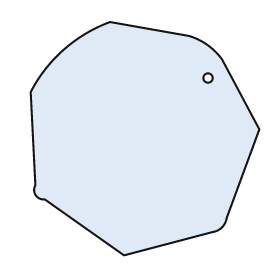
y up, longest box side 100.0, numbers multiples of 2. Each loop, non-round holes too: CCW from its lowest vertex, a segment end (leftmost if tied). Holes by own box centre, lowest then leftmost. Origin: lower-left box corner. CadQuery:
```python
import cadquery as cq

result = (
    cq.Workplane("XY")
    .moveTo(40.0, 0.0)
    .lineTo(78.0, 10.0)
    .threePointArc((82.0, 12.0), (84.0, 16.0))
    .lineTo(98.0, 54.0)
    .lineTo(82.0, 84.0)
    .threePointArc((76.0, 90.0), (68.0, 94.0))
    .lineTo(34.0, 100.0)
    .threePointArc((14.0, 88.0), (0.0, 70.0))
    .lineTo(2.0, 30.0)
    .threePointArc((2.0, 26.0), (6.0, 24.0))
    .close()
    .moveTo(76.0, 76.0)
    .circle(2.0)
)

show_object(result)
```